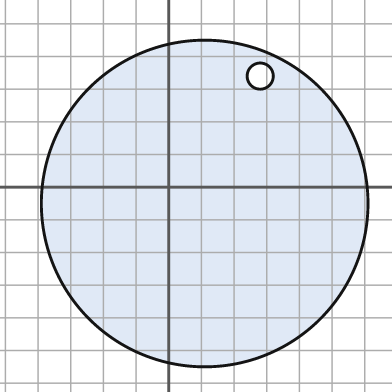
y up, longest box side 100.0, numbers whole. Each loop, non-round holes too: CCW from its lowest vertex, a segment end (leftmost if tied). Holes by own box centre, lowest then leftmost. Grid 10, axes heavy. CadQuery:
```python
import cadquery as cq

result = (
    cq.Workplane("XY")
    .moveTo(11.0, -5.0)
    .circle(50.0)
    .moveTo(28.0, 34.0)
    .circle(4.0)
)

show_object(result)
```